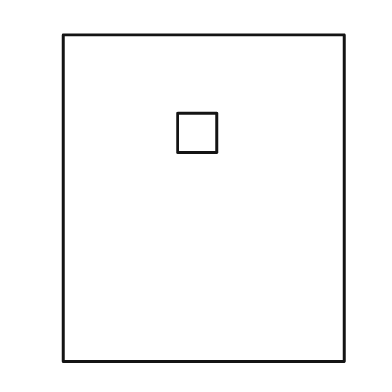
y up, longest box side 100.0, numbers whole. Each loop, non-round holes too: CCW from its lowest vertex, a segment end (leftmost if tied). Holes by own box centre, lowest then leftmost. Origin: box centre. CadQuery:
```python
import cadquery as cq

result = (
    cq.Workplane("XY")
    .moveTo(-43.0, -50.0)
    .lineTo(43.0, -50.0)
    .lineTo(43.0, 50.0)
    .lineTo(-43.0, 50.0)
    .close()
    .moveTo(-8.0, 14.0)
    .lineTo(4.0, 14.0)
    .lineTo(4.0, 26.0)
    .lineTo(-8.0, 26.0)
    .close()
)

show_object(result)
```